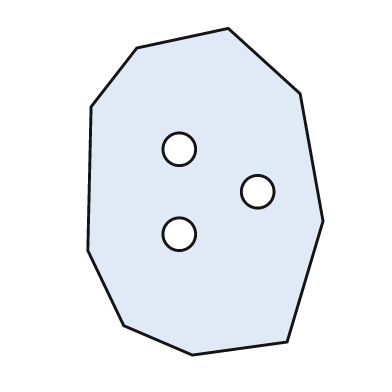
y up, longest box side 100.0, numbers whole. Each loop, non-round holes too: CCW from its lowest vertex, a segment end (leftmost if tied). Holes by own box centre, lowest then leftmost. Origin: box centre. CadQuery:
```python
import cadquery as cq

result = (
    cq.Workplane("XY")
    .moveTo(-4.0, -50.0)
    .lineTo(25.0, -46.0)
    .lineTo(36.0, -9.0)
    .lineTo(29.0, 30.0)
    .lineTo(7.0, 50.0)
    .lineTo(-21.0, 44.0)
    .lineTo(-35.0, 26.0)
    .lineTo(-36.0, -18.0)
    .lineTo(-25.0, -41.0)
    .close()
    .moveTo(-8.0, -13.0)
    .circle(5.0)
    .moveTo(16.0, 0.0)
    .circle(5.0)
    .moveTo(-8.0, 13.0)
    .circle(5.0)
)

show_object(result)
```